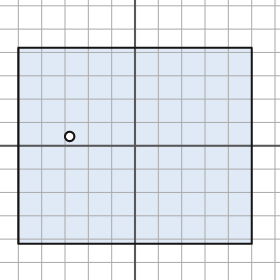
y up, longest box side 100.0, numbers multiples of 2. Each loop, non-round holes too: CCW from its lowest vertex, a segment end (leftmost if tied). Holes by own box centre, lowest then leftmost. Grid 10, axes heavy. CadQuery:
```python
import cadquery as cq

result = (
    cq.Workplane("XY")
    .moveTo(-50.0, -42.0)
    .lineTo(50.0, -42.0)
    .lineTo(50.0, 42.0)
    .lineTo(-50.0, 42.0)
    .close()
    .moveTo(-28.0, 4.0)
    .circle(2.0)
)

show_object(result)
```